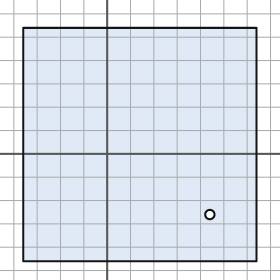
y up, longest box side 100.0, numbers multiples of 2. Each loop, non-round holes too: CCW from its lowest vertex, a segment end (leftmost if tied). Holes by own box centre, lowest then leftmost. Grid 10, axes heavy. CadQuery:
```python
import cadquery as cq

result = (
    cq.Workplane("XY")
    .moveTo(-36.0, -46.0)
    .lineTo(64.0, -46.0)
    .lineTo(64.0, 54.0)
    .lineTo(-36.0, 54.0)
    .close()
    .moveTo(44.0, -26.0)
    .circle(2.0)
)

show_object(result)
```